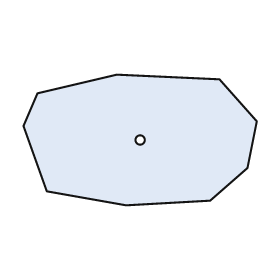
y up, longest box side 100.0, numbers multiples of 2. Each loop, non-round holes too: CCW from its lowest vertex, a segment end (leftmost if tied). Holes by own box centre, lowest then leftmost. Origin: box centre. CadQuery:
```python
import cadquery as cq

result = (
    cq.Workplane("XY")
    .moveTo(-6.0, -28.0)
    .lineTo(30.0, -26.0)
    .lineTo(46.0, -12.0)
    .lineTo(50.0, 8.0)
    .lineTo(34.0, 26.0)
    .lineTo(-10.0, 28.0)
    .lineTo(-44.0, 20.0)
    .lineTo(-50.0, 6.0)
    .lineTo(-40.0, -22.0)
    .close()
    .moveTo(0.0, 0.0)
    .circle(2.0)
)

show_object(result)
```